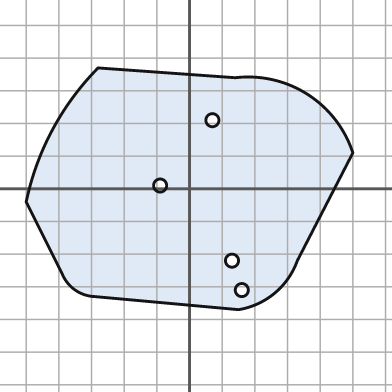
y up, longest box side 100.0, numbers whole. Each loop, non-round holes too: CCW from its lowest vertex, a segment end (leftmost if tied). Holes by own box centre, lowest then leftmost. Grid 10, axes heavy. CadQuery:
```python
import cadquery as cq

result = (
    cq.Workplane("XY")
    .moveTo(15.0, -37.0)
    .threePointArc((26.0, -32.0), (33.0, -22.0))
    .lineTo(50.0, 11.0)
    .threePointArc((36.0, 29.0), (14.0, 34.0))
    .lineTo(-28.0, 37.0)
    .threePointArc((-42.0, 18.0), (-50.0, -4.0))
    .lineTo(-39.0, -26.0)
    .threePointArc((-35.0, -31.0), (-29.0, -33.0))
    .close()
    .moveTo(16.0, -31.0)
    .circle(2.0)
    .moveTo(13.0, -22.0)
    .circle(2.0)
    .moveTo(-9.0, 1.0)
    .circle(2.0)
    .moveTo(7.0, 21.0)
    .circle(2.0)
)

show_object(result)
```